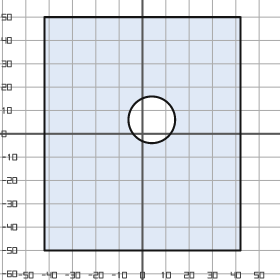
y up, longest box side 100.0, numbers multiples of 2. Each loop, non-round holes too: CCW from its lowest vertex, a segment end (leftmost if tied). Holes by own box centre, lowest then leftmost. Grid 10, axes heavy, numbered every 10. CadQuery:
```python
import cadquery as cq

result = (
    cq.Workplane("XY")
    .moveTo(-42.0, -50.0)
    .lineTo(42.0, -50.0)
    .lineTo(42.0, 50.0)
    .lineTo(-42.0, 50.0)
    .close()
    .moveTo(4.0, 6.0)
    .circle(10.0)
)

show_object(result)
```